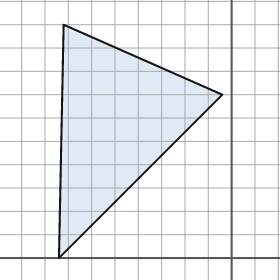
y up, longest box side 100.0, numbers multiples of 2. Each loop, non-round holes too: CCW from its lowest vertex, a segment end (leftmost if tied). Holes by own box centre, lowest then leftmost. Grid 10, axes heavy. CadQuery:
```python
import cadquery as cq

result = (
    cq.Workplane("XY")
    .moveTo(-74.0, 0.0)
    .lineTo(-4.0, 70.0)
    .lineTo(-72.0, 100.0)
    .close()
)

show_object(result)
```